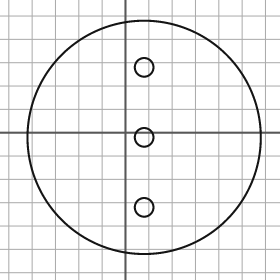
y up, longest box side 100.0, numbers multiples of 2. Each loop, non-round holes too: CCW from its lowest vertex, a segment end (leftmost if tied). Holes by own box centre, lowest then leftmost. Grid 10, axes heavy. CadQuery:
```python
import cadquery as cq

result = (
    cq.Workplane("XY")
    .moveTo(8.0, -2.0)
    .circle(50.0)
    .moveTo(8.0, -32.0)
    .circle(4.0)
    .moveTo(8.0, -2.0)
    .circle(4.0)
    .moveTo(8.0, 28.0)
    .circle(4.0)
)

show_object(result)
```